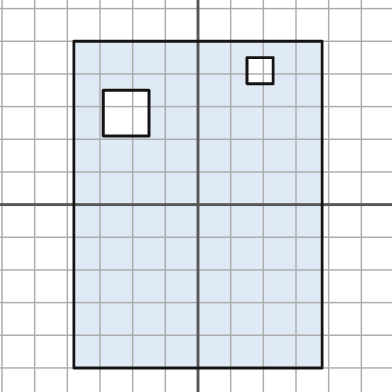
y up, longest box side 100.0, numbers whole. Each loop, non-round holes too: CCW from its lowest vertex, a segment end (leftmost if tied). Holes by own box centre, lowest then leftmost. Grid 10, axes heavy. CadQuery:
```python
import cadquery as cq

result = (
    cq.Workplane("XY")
    .moveTo(-38.0, -50.0)
    .lineTo(38.0, -50.0)
    .lineTo(38.0, 50.0)
    .lineTo(-38.0, 50.0)
    .close()
    .moveTo(-29.0, 21.0)
    .lineTo(-15.0, 21.0)
    .lineTo(-15.0, 35.0)
    .lineTo(-29.0, 35.0)
    .close()
    .moveTo(15.0, 37.0)
    .lineTo(23.0, 37.0)
    .lineTo(23.0, 45.0)
    .lineTo(15.0, 45.0)
    .close()
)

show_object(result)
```